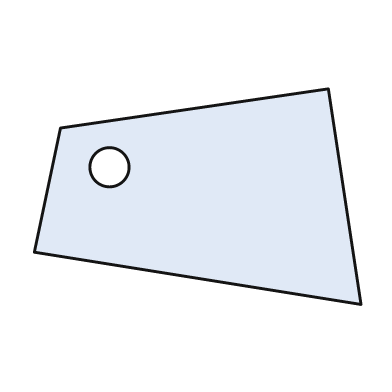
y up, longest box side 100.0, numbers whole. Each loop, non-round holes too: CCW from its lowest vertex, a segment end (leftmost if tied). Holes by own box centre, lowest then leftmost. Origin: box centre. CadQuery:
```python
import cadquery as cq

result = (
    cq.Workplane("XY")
    .moveTo(50.0, -33.0)
    .lineTo(40.0, 33.0)
    .lineTo(-42.0, 21.0)
    .lineTo(-50.0, -17.0)
    .close()
    .moveTo(-27.0, 9.0)
    .circle(6.0)
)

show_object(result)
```